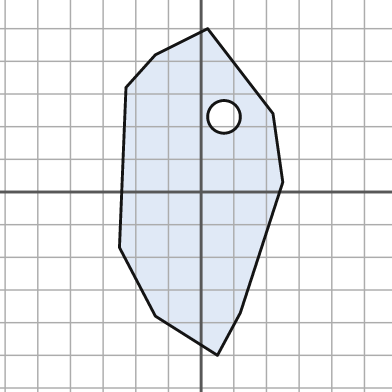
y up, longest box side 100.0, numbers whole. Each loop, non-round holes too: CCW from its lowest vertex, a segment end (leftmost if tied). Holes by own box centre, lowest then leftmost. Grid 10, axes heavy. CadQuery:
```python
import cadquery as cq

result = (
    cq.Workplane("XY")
    .moveTo(5.0, -50.0)
    .lineTo(12.0, -37.0)
    .lineTo(25.0, 3.0)
    .lineTo(22.0, 24.0)
    .lineTo(2.0, 50.0)
    .lineTo(-14.0, 42.0)
    .lineTo(-23.0, 32.0)
    .lineTo(-25.0, -17.0)
    .lineTo(-14.0, -38.0)
    .close()
    .moveTo(7.0, 23.0)
    .circle(5.0)
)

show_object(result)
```